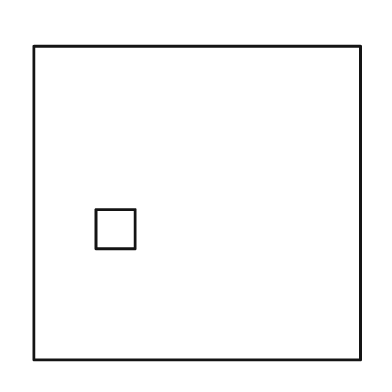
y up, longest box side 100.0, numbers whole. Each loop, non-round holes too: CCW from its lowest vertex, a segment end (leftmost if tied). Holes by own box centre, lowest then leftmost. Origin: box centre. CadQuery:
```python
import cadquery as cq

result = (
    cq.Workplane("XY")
    .moveTo(-50.0, -48.0)
    .lineTo(50.0, -48.0)
    .lineTo(50.0, 48.0)
    .lineTo(-50.0, 48.0)
    .close()
    .moveTo(-31.0, -14.0)
    .lineTo(-19.0, -14.0)
    .lineTo(-19.0, -2.0)
    .lineTo(-31.0, -2.0)
    .close()
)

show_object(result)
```